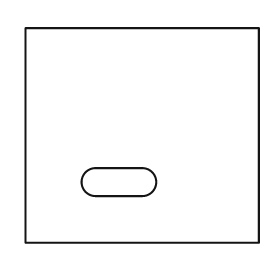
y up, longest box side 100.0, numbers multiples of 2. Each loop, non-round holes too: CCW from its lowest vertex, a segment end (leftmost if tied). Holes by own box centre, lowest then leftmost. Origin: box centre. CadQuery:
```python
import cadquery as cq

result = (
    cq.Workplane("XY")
    .moveTo(-50.0, -46.0)
    .lineTo(50.0, -46.0)
    .lineTo(50.0, 46.0)
    .lineTo(-50.0, 46.0)
    .close()
    .moveTo(-20.0, -26.0)
    .lineTo(0.0, -26.0)
    .threePointArc((6.0, -20.0), (0.0, -14.0))
    .lineTo(-20.0, -14.0)
    .threePointArc((-26.0, -20.0), (-20.0, -26.0))
    .close()
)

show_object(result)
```